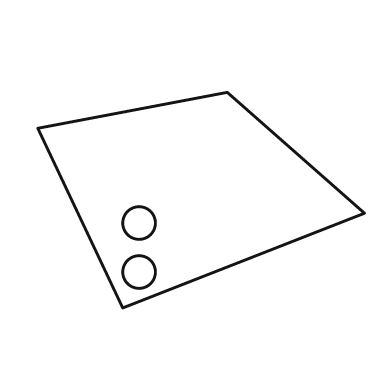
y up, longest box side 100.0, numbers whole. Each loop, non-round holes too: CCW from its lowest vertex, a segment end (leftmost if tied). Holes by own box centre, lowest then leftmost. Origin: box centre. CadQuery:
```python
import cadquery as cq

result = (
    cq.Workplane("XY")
    .moveTo(-24.0, -33.0)
    .lineTo(50.0, -4.0)
    .lineTo(8.0, 33.0)
    .lineTo(-50.0, 22.0)
    .close()
    .moveTo(-19.0, -22.0)
    .circle(5.0)
    .moveTo(-19.0, -7.0)
    .circle(5.0)
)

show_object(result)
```